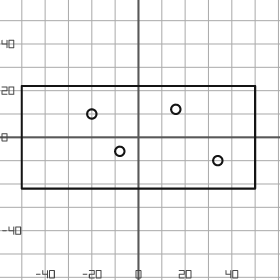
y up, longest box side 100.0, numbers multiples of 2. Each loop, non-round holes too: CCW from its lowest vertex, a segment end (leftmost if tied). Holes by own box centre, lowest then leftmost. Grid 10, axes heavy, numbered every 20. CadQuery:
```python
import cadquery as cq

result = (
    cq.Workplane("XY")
    .moveTo(-50.0, -22.0)
    .lineTo(50.0, -22.0)
    .lineTo(50.0, 22.0)
    .lineTo(-50.0, 22.0)
    .close()
    .moveTo(34.0, -10.0)
    .circle(2.0)
    .moveTo(-8.0, -6.0)
    .circle(2.0)
    .moveTo(-20.0, 10.0)
    .circle(2.0)
    .moveTo(16.0, 12.0)
    .circle(2.0)
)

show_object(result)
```